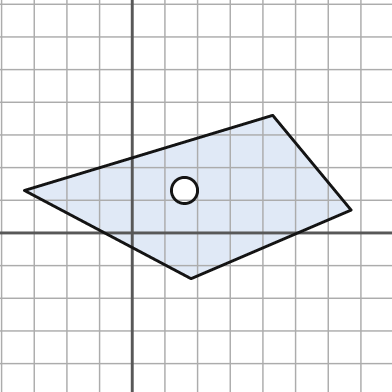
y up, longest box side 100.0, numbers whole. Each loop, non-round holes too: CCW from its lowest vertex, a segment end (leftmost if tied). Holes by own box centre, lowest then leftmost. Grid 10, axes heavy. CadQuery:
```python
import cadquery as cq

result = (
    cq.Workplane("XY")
    .moveTo(18.0, -14.0)
    .lineTo(67.0, 7.0)
    .lineTo(43.0, 36.0)
    .lineTo(-33.0, 13.0)
    .close()
    .moveTo(16.0, 13.0)
    .circle(4.0)
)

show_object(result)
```